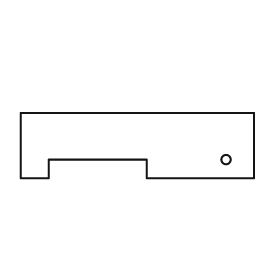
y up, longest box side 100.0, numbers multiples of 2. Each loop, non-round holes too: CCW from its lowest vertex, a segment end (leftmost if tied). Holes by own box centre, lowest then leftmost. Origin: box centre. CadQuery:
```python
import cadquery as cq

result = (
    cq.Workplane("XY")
    .moveTo(-50.0, -14.0)
    .lineTo(-38.0, -14.0)
    .lineTo(-38.0, -6.0)
    .lineTo(4.0, -6.0)
    .lineTo(4.0, -14.0)
    .lineTo(50.0, -14.0)
    .lineTo(50.0, 14.0)
    .lineTo(-50.0, 14.0)
    .close()
    .moveTo(38.0, -6.0)
    .circle(2.0)
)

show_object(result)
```